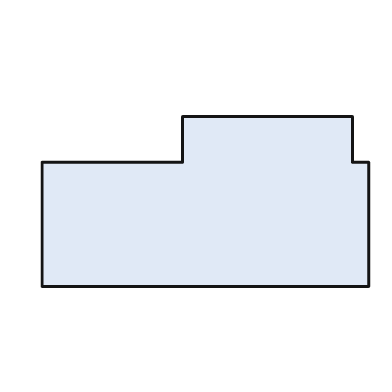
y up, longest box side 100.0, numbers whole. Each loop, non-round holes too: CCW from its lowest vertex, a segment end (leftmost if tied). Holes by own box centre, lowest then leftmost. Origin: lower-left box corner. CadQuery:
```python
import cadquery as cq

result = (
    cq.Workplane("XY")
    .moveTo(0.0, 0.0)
    .lineTo(100.0, 0.0)
    .lineTo(100.0, 38.0)
    .lineTo(95.0, 38.0)
    .lineTo(95.0, 52.0)
    .lineTo(43.0, 52.0)
    .lineTo(43.0, 38.0)
    .lineTo(0.0, 38.0)
    .close()
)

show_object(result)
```